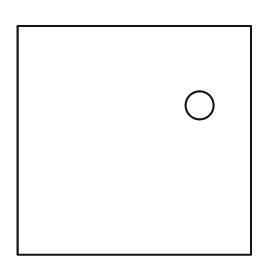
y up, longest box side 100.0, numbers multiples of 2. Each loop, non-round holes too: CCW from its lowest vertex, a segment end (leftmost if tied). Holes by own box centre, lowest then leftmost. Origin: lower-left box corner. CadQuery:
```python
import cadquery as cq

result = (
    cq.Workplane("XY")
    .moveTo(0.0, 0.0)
    .lineTo(100.0, 0.0)
    .lineTo(100.0, 98.0)
    .lineTo(0.0, 98.0)
    .close()
    .moveTo(78.0, 64.0)
    .circle(6.0)
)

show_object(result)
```